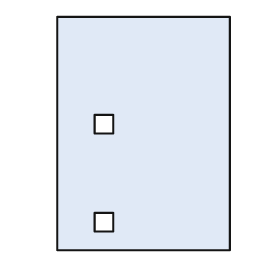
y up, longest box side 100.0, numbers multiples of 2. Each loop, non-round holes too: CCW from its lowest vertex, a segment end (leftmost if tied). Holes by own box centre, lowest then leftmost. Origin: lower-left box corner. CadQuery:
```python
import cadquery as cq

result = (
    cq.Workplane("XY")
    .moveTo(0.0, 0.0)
    .lineTo(74.0, 0.0)
    .lineTo(74.0, 100.0)
    .lineTo(0.0, 100.0)
    .close()
    .moveTo(16.0, 8.0)
    .lineTo(24.0, 8.0)
    .lineTo(24.0, 16.0)
    .lineTo(16.0, 16.0)
    .close()
    .moveTo(16.0, 50.0)
    .lineTo(24.0, 50.0)
    .lineTo(24.0, 58.0)
    .lineTo(16.0, 58.0)
    .close()
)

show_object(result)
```